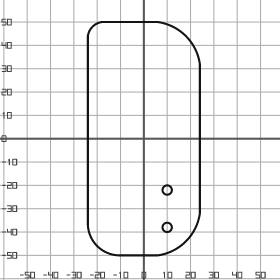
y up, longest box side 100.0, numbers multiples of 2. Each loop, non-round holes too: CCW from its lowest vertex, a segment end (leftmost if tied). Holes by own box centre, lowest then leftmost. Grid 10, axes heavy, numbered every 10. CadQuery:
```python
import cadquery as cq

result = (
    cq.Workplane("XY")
    .moveTo(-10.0, -50.0)
    .lineTo(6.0, -50.0)
    .threePointArc((18.0, -44.0), (24.0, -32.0))
    .lineTo(24.0, 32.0)
    .threePointArc((18.0, 44.0), (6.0, 50.0))
    .lineTo(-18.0, 50.0)
    .threePointArc((-22.0, 48.0), (-24.0, 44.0))
    .lineTo(-24.0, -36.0)
    .threePointArc((-20.0, -46.0), (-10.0, -50.0))
    .close()
    .moveTo(10.0, -38.0)
    .circle(2.0)
    .moveTo(10.0, -22.0)
    .circle(2.0)
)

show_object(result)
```